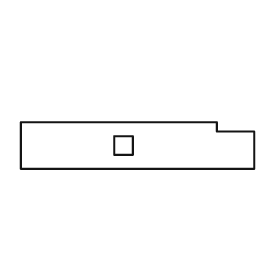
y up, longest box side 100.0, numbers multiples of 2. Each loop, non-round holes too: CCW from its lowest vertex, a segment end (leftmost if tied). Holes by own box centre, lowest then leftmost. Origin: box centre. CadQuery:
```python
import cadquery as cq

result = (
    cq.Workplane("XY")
    .moveTo(-50.0, -10.0)
    .lineTo(50.0, -10.0)
    .lineTo(50.0, 6.0)
    .lineTo(34.0, 6.0)
    .lineTo(34.0, 10.0)
    .lineTo(-50.0, 10.0)
    .close()
    .moveTo(-10.0, -4.0)
    .lineTo(-2.0, -4.0)
    .lineTo(-2.0, 4.0)
    .lineTo(-10.0, 4.0)
    .close()
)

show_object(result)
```